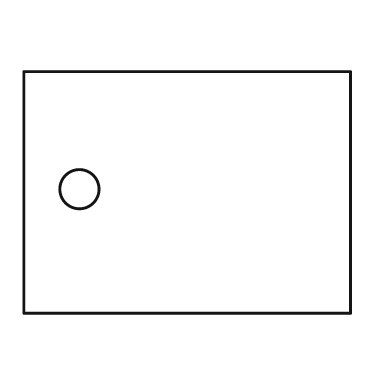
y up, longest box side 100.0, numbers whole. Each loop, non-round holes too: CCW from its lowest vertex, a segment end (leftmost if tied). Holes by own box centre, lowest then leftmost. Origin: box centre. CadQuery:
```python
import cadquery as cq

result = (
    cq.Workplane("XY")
    .moveTo(-50.0, -37.0)
    .lineTo(50.0, -37.0)
    .lineTo(50.0, 37.0)
    .lineTo(-50.0, 37.0)
    .close()
    .moveTo(-33.0, 1.0)
    .circle(6.0)
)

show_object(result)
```